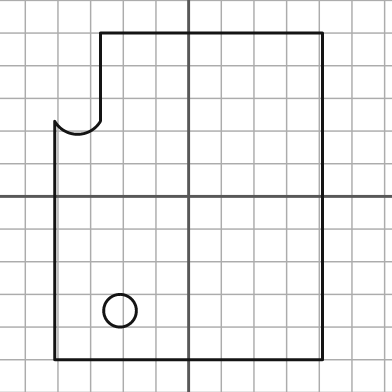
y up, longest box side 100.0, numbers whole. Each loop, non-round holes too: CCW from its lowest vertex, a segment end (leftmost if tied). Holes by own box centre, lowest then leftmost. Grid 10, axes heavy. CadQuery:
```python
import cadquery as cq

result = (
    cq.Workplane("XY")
    .moveTo(-41.0, -50.0)
    .lineTo(41.0, -50.0)
    .lineTo(41.0, 50.0)
    .lineTo(-27.0, 50.0)
    .lineTo(-27.0, 23.0)
    .threePointArc((-34.0, 19.0), (-41.0, 23.0))
    .close()
    .moveTo(-21.0, -35.0)
    .circle(5.0)
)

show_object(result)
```